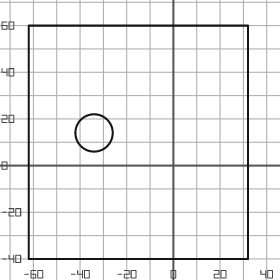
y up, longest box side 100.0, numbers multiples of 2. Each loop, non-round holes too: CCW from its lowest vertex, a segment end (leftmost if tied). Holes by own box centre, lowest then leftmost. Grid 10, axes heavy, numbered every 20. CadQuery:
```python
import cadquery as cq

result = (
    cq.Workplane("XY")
    .moveTo(-62.0, -40.0)
    .lineTo(32.0, -40.0)
    .lineTo(32.0, 60.0)
    .lineTo(-62.0, 60.0)
    .close()
    .moveTo(-34.0, 14.0)
    .circle(8.0)
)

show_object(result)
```